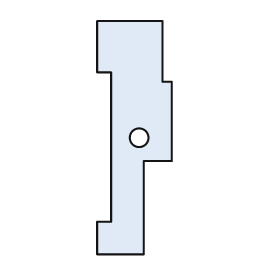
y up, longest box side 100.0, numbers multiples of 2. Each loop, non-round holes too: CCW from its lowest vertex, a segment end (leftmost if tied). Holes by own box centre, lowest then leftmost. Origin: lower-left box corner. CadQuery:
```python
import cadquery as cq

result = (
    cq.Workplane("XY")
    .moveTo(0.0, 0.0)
    .lineTo(20.0, 0.0)
    .lineTo(20.0, 40.0)
    .lineTo(32.0, 40.0)
    .lineTo(32.0, 74.0)
    .lineTo(28.0, 74.0)
    .lineTo(28.0, 100.0)
    .lineTo(0.0, 100.0)
    .lineTo(0.0, 78.0)
    .lineTo(6.0, 78.0)
    .lineTo(6.0, 14.0)
    .lineTo(0.0, 14.0)
    .close()
    .moveTo(18.0, 50.0)
    .circle(4.0)
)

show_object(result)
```